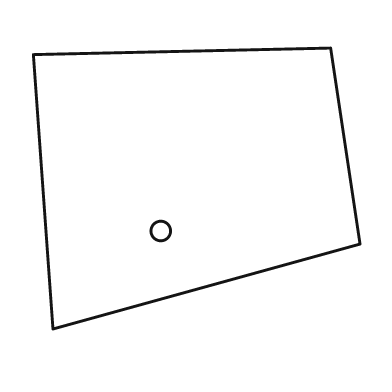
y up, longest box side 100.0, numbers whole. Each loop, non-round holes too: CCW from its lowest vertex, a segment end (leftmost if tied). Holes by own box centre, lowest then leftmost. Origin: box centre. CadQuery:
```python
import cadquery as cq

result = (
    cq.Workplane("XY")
    .moveTo(-44.0, -43.0)
    .lineTo(50.0, -17.0)
    .lineTo(41.0, 43.0)
    .lineTo(-50.0, 41.0)
    .close()
    .moveTo(-11.0, -13.0)
    .circle(3.0)
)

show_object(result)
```